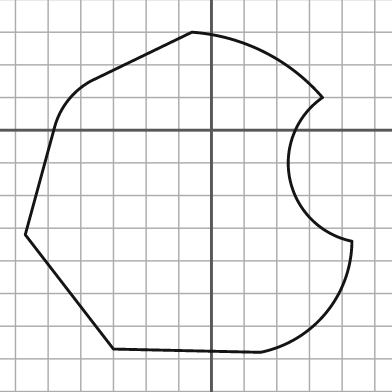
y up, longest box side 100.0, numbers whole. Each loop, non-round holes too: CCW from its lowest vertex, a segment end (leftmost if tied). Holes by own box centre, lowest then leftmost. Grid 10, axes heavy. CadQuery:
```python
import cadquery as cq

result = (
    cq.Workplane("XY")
    .moveTo(15.0, -68.0)
    .threePointArc((35.0, -56.0), (43.0, -34.0))
    .threePointArc((24.0, -15.0), (34.0, 10.0))
    .threePointArc((16.0, 24.0), (-6.0, 30.0))
    .lineTo(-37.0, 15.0)
    .threePointArc((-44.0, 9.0), (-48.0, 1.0))
    .lineTo(-57.0, -32.0)
    .lineTo(-30.0, -67.0)
    .close()
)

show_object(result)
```